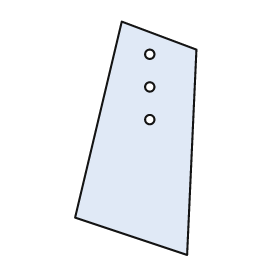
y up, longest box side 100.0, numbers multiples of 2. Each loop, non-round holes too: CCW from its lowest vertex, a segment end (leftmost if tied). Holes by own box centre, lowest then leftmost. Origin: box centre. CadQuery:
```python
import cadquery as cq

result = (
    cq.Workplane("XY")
    .moveTo(22.0, -50.0)
    .lineTo(26.0, 38.0)
    .lineTo(-6.0, 50.0)
    .lineTo(-26.0, -34.0)
    .close()
    .moveTo(6.0, 8.0)
    .circle(2.0)
    .moveTo(6.0, 22.0)
    .circle(2.0)
    .moveTo(6.0, 36.0)
    .circle(2.0)
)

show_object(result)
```